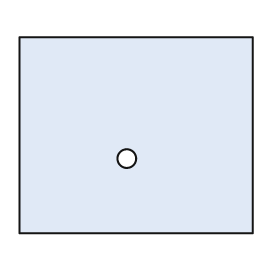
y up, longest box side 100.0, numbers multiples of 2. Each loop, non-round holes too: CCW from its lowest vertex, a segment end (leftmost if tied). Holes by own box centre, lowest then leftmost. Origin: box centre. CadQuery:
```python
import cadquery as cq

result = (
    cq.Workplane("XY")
    .moveTo(-50.0, -42.0)
    .lineTo(50.0, -42.0)
    .lineTo(50.0, 42.0)
    .lineTo(-50.0, 42.0)
    .close()
    .moveTo(-4.0, -10.0)
    .circle(4.0)
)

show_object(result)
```